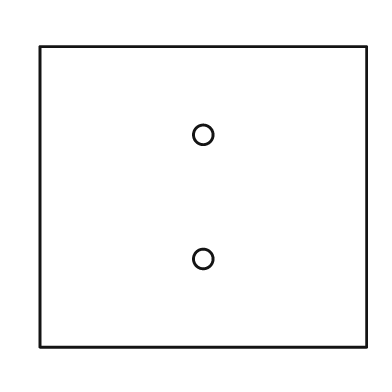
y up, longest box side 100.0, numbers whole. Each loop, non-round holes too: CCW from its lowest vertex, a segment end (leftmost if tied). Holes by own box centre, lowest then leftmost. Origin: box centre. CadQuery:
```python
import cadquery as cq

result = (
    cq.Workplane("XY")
    .moveTo(-50.0, -46.0)
    .lineTo(50.0, -46.0)
    .lineTo(50.0, 46.0)
    .lineTo(-50.0, 46.0)
    .close()
    .moveTo(0.0, -19.0)
    .circle(3.0)
    .moveTo(0.0, 19.0)
    .circle(3.0)
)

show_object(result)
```